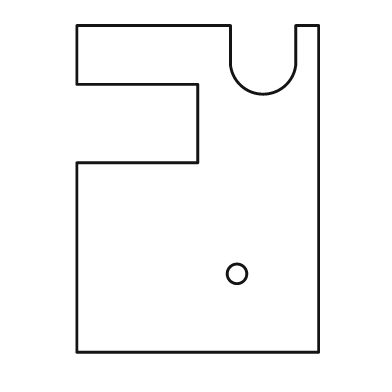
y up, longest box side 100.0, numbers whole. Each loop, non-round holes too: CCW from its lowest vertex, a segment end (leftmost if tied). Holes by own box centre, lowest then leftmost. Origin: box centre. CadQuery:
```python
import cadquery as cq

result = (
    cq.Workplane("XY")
    .moveTo(-37.0, -50.0)
    .lineTo(37.0, -50.0)
    .lineTo(37.0, 50.0)
    .lineTo(30.0, 50.0)
    .lineTo(30.0, 38.0)
    .threePointArc((20.0, 29.0), (10.0, 38.0))
    .lineTo(10.0, 50.0)
    .lineTo(-37.0, 50.0)
    .lineTo(-37.0, 32.0)
    .lineTo(0.0, 32.0)
    .lineTo(0.0, 8.0)
    .lineTo(-37.0, 8.0)
    .close()
    .moveTo(12.0, -26.0)
    .circle(3.0)
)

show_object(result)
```